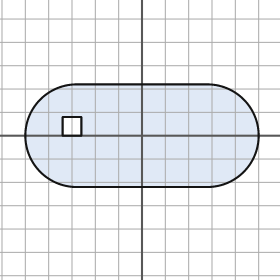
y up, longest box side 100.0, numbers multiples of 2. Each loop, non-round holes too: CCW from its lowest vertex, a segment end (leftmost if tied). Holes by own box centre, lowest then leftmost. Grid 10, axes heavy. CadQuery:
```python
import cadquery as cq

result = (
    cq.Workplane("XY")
    .moveTo(-28.0, -22.0)
    .lineTo(28.0, -22.0)
    .threePointArc((50.0, 0.0), (28.0, 22.0))
    .lineTo(-28.0, 22.0)
    .threePointArc((-50.0, 0.0), (-28.0, -22.0))
    .close()
    .moveTo(-34.0, 0.0)
    .lineTo(-26.0, 0.0)
    .lineTo(-26.0, 8.0)
    .lineTo(-34.0, 8.0)
    .close()
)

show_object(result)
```